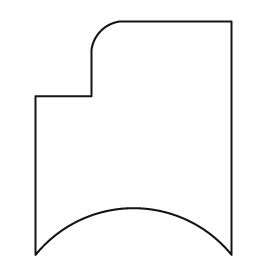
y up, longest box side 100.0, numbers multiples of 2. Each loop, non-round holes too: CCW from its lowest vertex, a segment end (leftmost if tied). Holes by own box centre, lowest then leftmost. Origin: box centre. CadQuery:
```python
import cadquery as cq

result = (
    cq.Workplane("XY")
    .moveTo(-42.0, -50.0)
    .threePointArc((0.0, -30.0), (42.0, -50.0))
    .lineTo(42.0, 50.0)
    .lineTo(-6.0, 50.0)
    .threePointArc((-14.0, 46.0), (-18.0, 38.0))
    .lineTo(-18.0, 18.0)
    .lineTo(-42.0, 18.0)
    .close()
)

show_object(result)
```